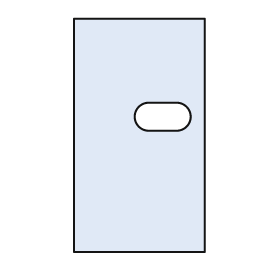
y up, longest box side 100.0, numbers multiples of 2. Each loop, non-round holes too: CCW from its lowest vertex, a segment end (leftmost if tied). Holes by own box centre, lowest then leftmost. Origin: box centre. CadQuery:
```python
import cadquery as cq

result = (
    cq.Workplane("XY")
    .moveTo(-28.0, -50.0)
    .lineTo(28.0, -50.0)
    .lineTo(28.0, 50.0)
    .lineTo(-28.0, 50.0)
    .close()
    .moveTo(4.0, 2.0)
    .lineTo(16.0, 2.0)
    .threePointArc((22.0, 8.0), (16.0, 14.0))
    .lineTo(4.0, 14.0)
    .threePointArc((-2.0, 8.0), (4.0, 2.0))
    .close()
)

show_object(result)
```